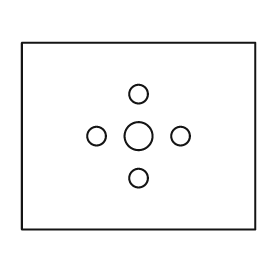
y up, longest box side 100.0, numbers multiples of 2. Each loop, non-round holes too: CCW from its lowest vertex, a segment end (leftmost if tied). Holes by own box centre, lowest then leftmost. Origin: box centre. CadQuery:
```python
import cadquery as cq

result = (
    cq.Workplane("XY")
    .moveTo(-50.0, -40.0)
    .lineTo(50.0, -40.0)
    .lineTo(50.0, 40.0)
    .lineTo(-50.0, 40.0)
    .close()
    .moveTo(0.0, -18.0)
    .circle(4.0)
    .moveTo(-18.0, 0.0)
    .circle(4.0)
    .moveTo(0.0, 0.0)
    .circle(6.0)
    .moveTo(18.0, 0.0)
    .circle(4.0)
    .moveTo(0.0, 18.0)
    .circle(4.0)
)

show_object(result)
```